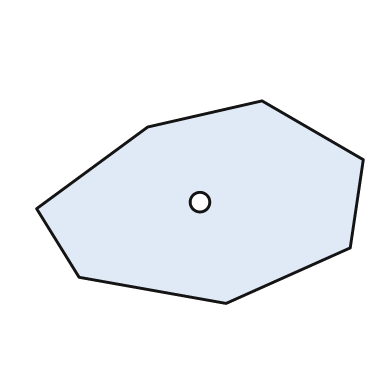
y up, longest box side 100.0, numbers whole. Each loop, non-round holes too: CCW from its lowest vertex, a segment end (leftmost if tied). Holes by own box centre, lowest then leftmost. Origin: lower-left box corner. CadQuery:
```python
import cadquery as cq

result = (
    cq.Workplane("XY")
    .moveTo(58.0, 0.0)
    .lineTo(96.0, 17.0)
    .lineTo(100.0, 44.0)
    .lineTo(69.0, 62.0)
    .lineTo(34.0, 54.0)
    .lineTo(0.0, 29.0)
    .lineTo(13.0, 8.0)
    .close()
    .moveTo(50.0, 31.0)
    .circle(3.0)
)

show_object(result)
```